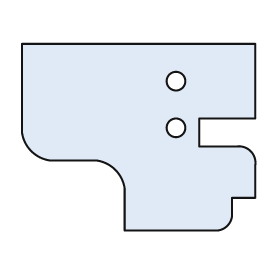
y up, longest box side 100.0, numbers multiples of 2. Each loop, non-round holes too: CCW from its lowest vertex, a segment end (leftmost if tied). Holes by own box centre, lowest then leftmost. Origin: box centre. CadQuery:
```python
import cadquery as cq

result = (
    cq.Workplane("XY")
    .moveTo(-6.0, -40.0)
    .lineTo(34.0, -40.0)
    .threePointArc((38.0, -38.0), (40.0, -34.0))
    .lineTo(40.0, -26.0)
    .lineTo(50.0, -26.0)
    .lineTo(50.0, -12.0)
    .threePointArc((48.0, -6.0), (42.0, -4.0))
    .lineTo(26.0, -4.0)
    .lineTo(26.0, 8.0)
    .lineTo(50.0, 8.0)
    .lineTo(50.0, 40.0)
    .lineTo(-50.0, 40.0)
    .lineTo(-50.0, 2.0)
    .threePointArc((-46.0, -6.0), (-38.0, -10.0))
    .lineTo(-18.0, -10.0)
    .threePointArc((-10.0, -14.0), (-6.0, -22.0))
    .close()
    .moveTo(16.0, 4.0)
    .circle(4.0)
    .moveTo(16.0, 24.0)
    .circle(4.0)
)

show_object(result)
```